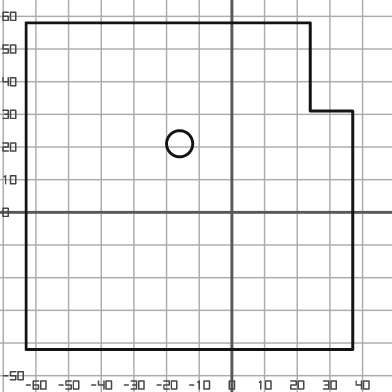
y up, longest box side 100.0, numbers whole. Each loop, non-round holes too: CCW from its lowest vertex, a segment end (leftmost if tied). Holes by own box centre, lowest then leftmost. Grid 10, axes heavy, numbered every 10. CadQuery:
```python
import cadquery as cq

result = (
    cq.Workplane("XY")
    .moveTo(-63.0, -42.0)
    .lineTo(37.0, -42.0)
    .lineTo(37.0, 31.0)
    .lineTo(24.0, 31.0)
    .lineTo(24.0, 58.0)
    .lineTo(-63.0, 58.0)
    .close()
    .moveTo(-16.0, 21.0)
    .circle(4.0)
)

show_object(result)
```